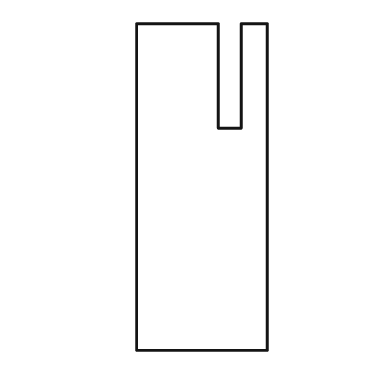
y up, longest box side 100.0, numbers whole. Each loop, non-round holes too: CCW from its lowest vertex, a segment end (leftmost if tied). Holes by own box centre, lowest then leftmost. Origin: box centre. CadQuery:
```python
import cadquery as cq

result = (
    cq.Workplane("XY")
    .moveTo(-20.0, -50.0)
    .lineTo(20.0, -50.0)
    .lineTo(20.0, 50.0)
    .lineTo(12.0, 50.0)
    .lineTo(12.0, 18.0)
    .lineTo(5.0, 18.0)
    .lineTo(5.0, 50.0)
    .lineTo(-20.0, 50.0)
    .close()
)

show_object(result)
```